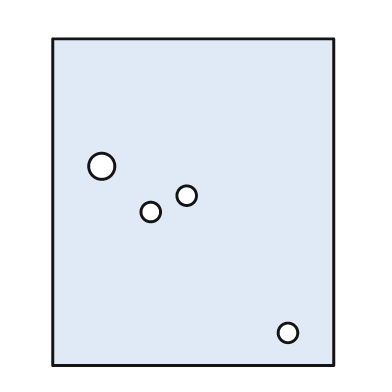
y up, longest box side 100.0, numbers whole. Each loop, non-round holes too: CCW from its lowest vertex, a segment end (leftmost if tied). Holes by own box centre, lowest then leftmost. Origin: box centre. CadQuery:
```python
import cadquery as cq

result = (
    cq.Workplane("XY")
    .moveTo(-43.0, -50.0)
    .lineTo(43.0, -50.0)
    .lineTo(43.0, 50.0)
    .lineTo(-43.0, 50.0)
    .close()
    .moveTo(29.0, -40.0)
    .circle(3.0)
    .moveTo(-13.0, -3.0)
    .circle(3.0)
    .moveTo(-2.0, 2.0)
    .circle(3.0)
    .moveTo(-28.0, 11.0)
    .circle(4.0)
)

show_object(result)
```